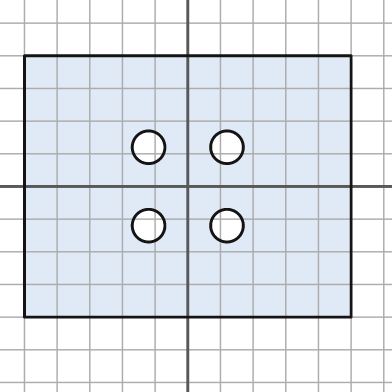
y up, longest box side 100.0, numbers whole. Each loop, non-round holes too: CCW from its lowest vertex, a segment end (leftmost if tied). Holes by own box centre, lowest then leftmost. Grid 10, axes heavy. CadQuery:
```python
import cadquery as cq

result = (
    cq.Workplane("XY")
    .moveTo(-50.0, -40.0)
    .lineTo(50.0, -40.0)
    .lineTo(50.0, 40.0)
    .lineTo(-50.0, 40.0)
    .close()
    .moveTo(-12.0, -12.0)
    .circle(5.0)
    .moveTo(12.0, -12.0)
    .circle(5.0)
    .moveTo(-12.0, 12.0)
    .circle(5.0)
    .moveTo(12.0, 12.0)
    .circle(5.0)
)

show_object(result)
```